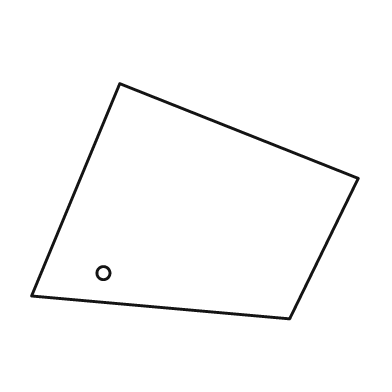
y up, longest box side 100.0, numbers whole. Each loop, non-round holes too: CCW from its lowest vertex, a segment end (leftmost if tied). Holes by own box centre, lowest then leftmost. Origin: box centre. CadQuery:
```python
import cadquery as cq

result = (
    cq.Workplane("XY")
    .moveTo(29.0, -36.0)
    .lineTo(50.0, 7.0)
    .lineTo(-23.0, 36.0)
    .lineTo(-50.0, -29.0)
    .close()
    .moveTo(-28.0, -22.0)
    .circle(2.0)
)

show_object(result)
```